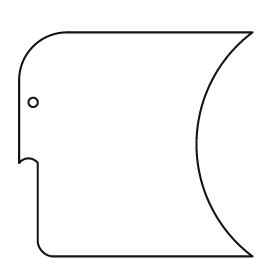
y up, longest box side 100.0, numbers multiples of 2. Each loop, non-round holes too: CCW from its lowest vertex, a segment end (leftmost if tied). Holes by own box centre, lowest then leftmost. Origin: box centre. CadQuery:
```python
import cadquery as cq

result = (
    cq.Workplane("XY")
    .moveTo(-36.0, -48.0)
    .lineTo(50.0, -48.0)
    .threePointArc((26.0, 0.0), (50.0, 48.0))
    .lineTo(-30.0, 48.0)
    .threePointArc((-44.0, 42.0), (-50.0, 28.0))
    .lineTo(-50.0, -8.0)
    .threePointArc((-46.0, -6.0), (-42.0, -8.0))
    .lineTo(-42.0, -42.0)
    .threePointArc((-40.0, -46.0), (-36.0, -48.0))
    .close()
    .moveTo(-44.0, 18.0)
    .circle(2.0)
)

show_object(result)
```